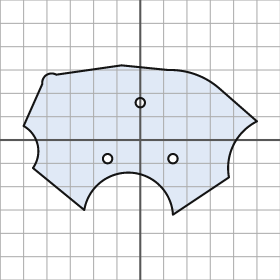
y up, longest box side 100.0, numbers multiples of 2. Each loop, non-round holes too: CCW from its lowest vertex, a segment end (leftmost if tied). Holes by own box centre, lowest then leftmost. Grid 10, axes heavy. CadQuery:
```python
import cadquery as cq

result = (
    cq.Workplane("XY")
    .moveTo(14.0, -32.0)
    .lineTo(38.0, -16.0)
    .threePointArc((40.0, -2.0), (50.0, 8.0))
    .lineTo(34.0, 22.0)
    .threePointArc((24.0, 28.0), (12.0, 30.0))
    .lineTo(-8.0, 32.0)
    .lineTo(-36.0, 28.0)
    .threePointArc((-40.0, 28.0), (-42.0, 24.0))
    .lineTo(-50.0, 6.0)
    .threePointArc((-44.0, -2.0), (-46.0, -12.0))
    .lineTo(-24.0, -30.0)
    .threePointArc((-4.0, -14.0), (14.0, -32.0))
    .close()
    .moveTo(-14.0, -8.0)
    .circle(2.0)
    .moveTo(14.0, -8.0)
    .circle(2.0)
    .moveTo(0.0, 16.0)
    .circle(2.0)
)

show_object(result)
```